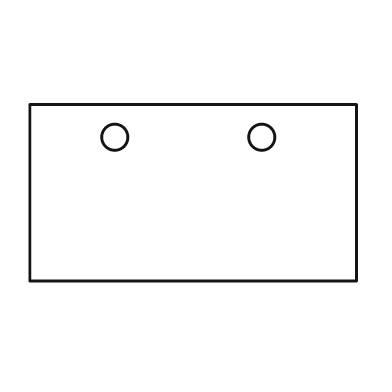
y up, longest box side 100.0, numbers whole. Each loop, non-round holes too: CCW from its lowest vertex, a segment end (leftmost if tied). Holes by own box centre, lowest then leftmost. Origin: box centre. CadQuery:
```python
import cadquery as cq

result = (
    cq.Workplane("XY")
    .moveTo(-50.0, -27.0)
    .lineTo(50.0, -27.0)
    .lineTo(50.0, 27.0)
    .lineTo(-50.0, 27.0)
    .close()
    .moveTo(-24.0, 17.0)
    .circle(4.0)
    .moveTo(21.0, 17.0)
    .circle(4.0)
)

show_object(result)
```